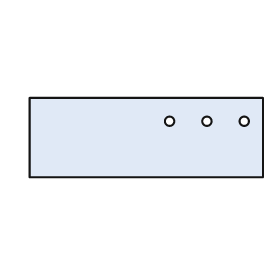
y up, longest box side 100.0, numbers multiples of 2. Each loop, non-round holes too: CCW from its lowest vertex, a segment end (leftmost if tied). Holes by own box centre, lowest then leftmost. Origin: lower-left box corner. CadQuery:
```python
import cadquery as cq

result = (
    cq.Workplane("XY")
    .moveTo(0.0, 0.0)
    .lineTo(100.0, 0.0)
    .lineTo(100.0, 34.0)
    .lineTo(0.0, 34.0)
    .close()
    .moveTo(60.0, 24.0)
    .circle(2.0)
    .moveTo(76.0, 24.0)
    .circle(2.0)
    .moveTo(92.0, 24.0)
    .circle(2.0)
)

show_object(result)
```